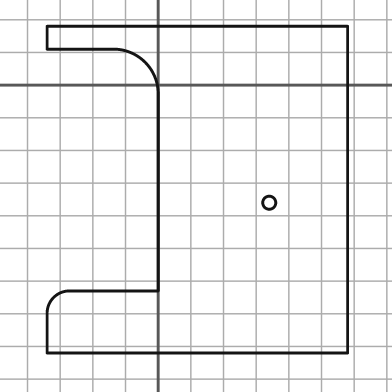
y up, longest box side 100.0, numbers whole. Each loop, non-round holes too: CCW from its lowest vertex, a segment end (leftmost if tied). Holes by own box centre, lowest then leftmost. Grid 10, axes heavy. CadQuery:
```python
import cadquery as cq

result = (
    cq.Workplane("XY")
    .moveTo(-34.0, -82.0)
    .lineTo(58.0, -82.0)
    .lineTo(58.0, 18.0)
    .lineTo(-34.0, 18.0)
    .lineTo(-34.0, 11.0)
    .lineTo(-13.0, 11.0)
    .threePointArc((-4.0, 7.0), (0.0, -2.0))
    .lineTo(0.0, -63.0)
    .lineTo(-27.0, -63.0)
    .threePointArc((-32.0, -65.0), (-34.0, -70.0))
    .close()
    .moveTo(34.0, -36.0)
    .circle(2.0)
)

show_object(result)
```